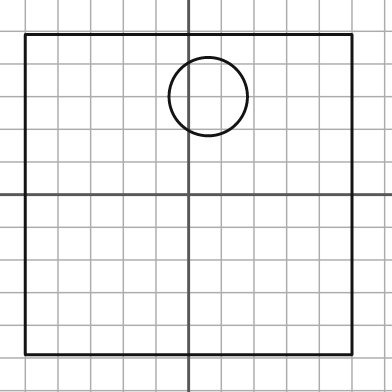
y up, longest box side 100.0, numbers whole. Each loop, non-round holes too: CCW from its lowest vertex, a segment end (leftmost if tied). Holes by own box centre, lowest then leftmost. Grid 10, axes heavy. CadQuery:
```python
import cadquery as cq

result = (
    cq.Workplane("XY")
    .moveTo(-50.0, -49.0)
    .lineTo(50.0, -49.0)
    .lineTo(50.0, 49.0)
    .lineTo(-50.0, 49.0)
    .close()
    .moveTo(6.0, 30.0)
    .circle(12.0)
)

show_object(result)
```